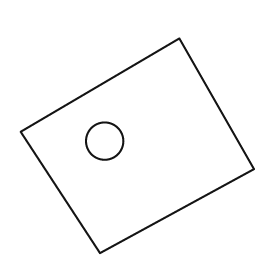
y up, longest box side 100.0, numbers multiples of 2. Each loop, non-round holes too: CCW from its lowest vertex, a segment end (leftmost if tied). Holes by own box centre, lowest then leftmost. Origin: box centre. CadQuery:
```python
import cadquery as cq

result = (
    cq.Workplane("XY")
    .moveTo(-16.0, -46.0)
    .lineTo(50.0, -10.0)
    .lineTo(18.0, 46.0)
    .lineTo(-50.0, 6.0)
    .close()
    .moveTo(-14.0, 2.0)
    .circle(8.0)
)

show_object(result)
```